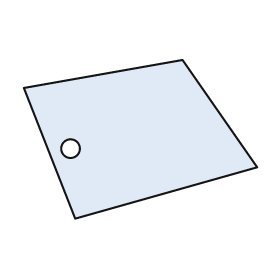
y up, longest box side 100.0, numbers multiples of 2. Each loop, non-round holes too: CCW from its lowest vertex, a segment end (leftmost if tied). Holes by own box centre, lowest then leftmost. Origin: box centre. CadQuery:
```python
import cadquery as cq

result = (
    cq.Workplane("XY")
    .moveTo(-28.0, -34.0)
    .lineTo(50.0, -12.0)
    .lineTo(18.0, 34.0)
    .lineTo(-50.0, 22.0)
    .close()
    .moveTo(-30.0, -4.0)
    .circle(4.0)
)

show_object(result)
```